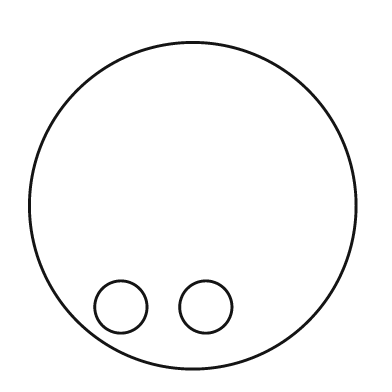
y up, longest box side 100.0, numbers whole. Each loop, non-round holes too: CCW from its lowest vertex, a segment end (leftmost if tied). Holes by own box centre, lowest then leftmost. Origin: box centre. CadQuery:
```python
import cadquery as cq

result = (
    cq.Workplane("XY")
    .moveTo(0.0, 0.0)
    .circle(50.0)
    .moveTo(-22.0, -31.0)
    .circle(8.0)
    .moveTo(4.0, -31.0)
    .circle(8.0)
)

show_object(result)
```